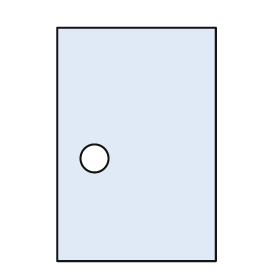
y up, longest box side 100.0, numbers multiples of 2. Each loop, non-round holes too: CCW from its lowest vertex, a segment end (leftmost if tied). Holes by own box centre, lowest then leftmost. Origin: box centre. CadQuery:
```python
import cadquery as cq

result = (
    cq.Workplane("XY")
    .moveTo(-34.0, -50.0)
    .lineTo(34.0, -50.0)
    .lineTo(34.0, 50.0)
    .lineTo(-34.0, 50.0)
    .close()
    .moveTo(-18.0, -6.0)
    .circle(6.0)
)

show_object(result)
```